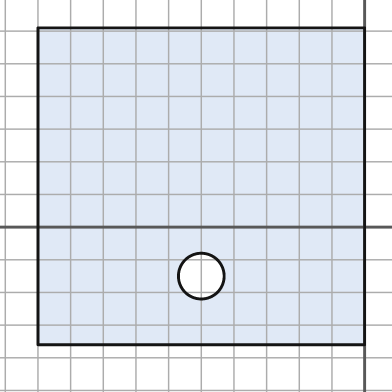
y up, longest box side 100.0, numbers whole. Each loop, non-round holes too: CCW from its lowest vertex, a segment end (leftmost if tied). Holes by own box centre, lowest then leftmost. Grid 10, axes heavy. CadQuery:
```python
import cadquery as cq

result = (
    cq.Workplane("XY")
    .moveTo(-100.0, -36.0)
    .lineTo(0.0, -36.0)
    .lineTo(0.0, 61.0)
    .lineTo(-100.0, 61.0)
    .close()
    .moveTo(-50.0, -15.0)
    .circle(7.0)
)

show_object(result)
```